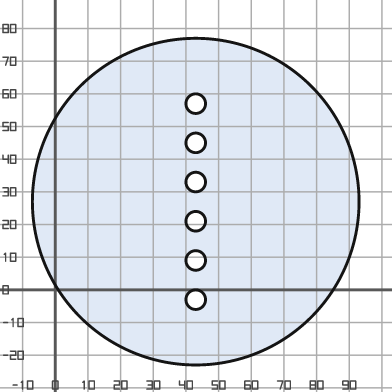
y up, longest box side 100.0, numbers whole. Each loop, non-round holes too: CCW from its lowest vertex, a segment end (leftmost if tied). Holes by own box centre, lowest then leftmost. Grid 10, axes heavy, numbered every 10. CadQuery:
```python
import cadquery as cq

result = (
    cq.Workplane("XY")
    .moveTo(43.0, 27.0)
    .circle(50.0)
    .moveTo(43.0, -3.0)
    .circle(3.0)
    .moveTo(43.0, 9.0)
    .circle(3.0)
    .moveTo(43.0, 21.0)
    .circle(3.0)
    .moveTo(43.0, 33.0)
    .circle(3.0)
    .moveTo(43.0, 45.0)
    .circle(3.0)
    .moveTo(43.0, 57.0)
    .circle(3.0)
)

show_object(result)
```